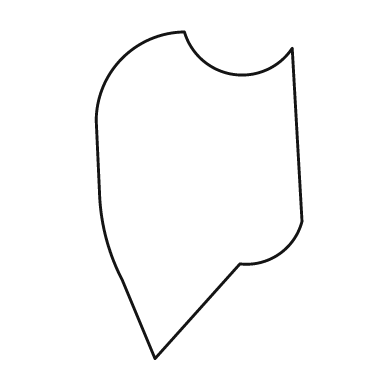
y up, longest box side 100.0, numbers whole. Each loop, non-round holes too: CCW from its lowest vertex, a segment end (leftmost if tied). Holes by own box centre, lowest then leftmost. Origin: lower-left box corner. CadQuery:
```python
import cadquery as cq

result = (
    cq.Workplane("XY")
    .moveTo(18.0, 0.0)
    .lineTo(44.0, 29.0)
    .threePointArc((56.0, 32.0), (63.0, 42.0))
    .lineTo(60.0, 95.0)
    .threePointArc((42.0, 87.0), (27.0, 100.0))
    .threePointArc((8.0, 92.0), (0.0, 73.0))
    .lineTo(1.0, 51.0)
    .threePointArc((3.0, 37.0), (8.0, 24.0))
    .close()
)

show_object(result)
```